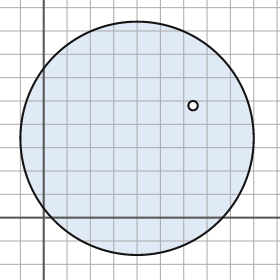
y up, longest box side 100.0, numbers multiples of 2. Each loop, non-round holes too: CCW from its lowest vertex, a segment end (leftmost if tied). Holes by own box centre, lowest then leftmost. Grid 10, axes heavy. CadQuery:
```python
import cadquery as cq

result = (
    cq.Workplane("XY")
    .moveTo(40.0, 34.0)
    .circle(50.0)
    .moveTo(64.0, 48.0)
    .circle(2.0)
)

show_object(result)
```